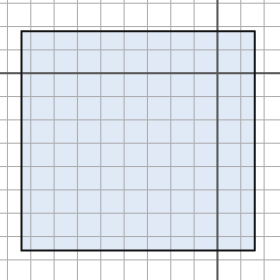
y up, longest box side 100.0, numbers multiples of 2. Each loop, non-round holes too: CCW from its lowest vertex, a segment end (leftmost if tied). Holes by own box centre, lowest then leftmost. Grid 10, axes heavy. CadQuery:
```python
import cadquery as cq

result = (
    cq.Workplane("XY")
    .moveTo(-84.0, -76.0)
    .lineTo(16.0, -76.0)
    .lineTo(16.0, 18.0)
    .lineTo(-84.0, 18.0)
    .close()
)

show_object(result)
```